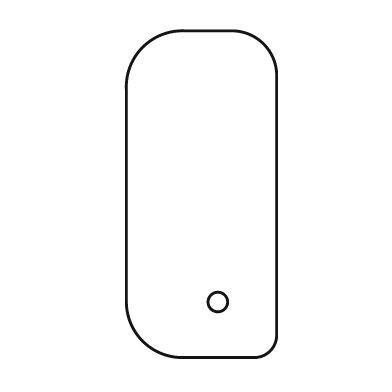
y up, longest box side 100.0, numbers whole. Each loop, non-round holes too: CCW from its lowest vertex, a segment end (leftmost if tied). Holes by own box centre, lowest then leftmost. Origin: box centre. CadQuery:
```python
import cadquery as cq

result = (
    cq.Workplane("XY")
    .moveTo(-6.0, -50.0)
    .lineTo(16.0, -50.0)
    .threePointArc((21.0, -48.0), (23.0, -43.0))
    .lineTo(23.0, 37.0)
    .threePointArc((19.0, 46.0), (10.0, 50.0))
    .lineTo(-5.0, 50.0)
    .threePointArc((-18.0, 45.0), (-23.0, 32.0))
    .lineTo(-23.0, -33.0)
    .threePointArc((-18.0, -45.0), (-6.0, -50.0))
    .close()
    .moveTo(5.0, -33.0)
    .circle(3.0)
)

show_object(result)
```